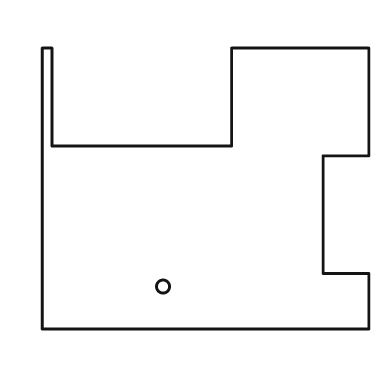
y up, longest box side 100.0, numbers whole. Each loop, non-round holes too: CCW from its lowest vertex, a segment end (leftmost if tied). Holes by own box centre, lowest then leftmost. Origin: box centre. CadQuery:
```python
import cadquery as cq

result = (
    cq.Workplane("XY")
    .moveTo(-50.0, -43.0)
    .lineTo(50.0, -43.0)
    .lineTo(50.0, -26.0)
    .lineTo(36.0, -26.0)
    .lineTo(36.0, 10.0)
    .lineTo(50.0, 10.0)
    .lineTo(50.0, 43.0)
    .lineTo(8.0, 43.0)
    .lineTo(8.0, 13.0)
    .lineTo(-47.0, 13.0)
    .lineTo(-47.0, 43.0)
    .lineTo(-50.0, 43.0)
    .close()
    .moveTo(-13.0, -30.0)
    .circle(2.0)
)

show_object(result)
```